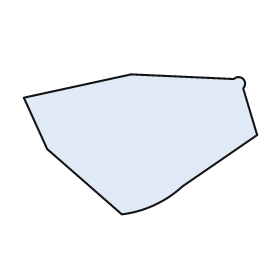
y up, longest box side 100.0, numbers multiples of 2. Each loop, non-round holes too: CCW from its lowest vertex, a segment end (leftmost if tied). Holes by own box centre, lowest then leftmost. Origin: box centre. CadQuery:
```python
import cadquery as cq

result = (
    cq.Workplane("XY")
    .moveTo(-8.0, -30.0)
    .threePointArc((6.0, -26.0), (18.0, -18.0))
    .lineTo(50.0, 4.0)
    .lineTo(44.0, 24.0)
    .threePointArc((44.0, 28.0), (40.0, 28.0))
    .lineTo(-4.0, 30.0)
    .lineTo(-50.0, 20.0)
    .lineTo(-40.0, -2.0)
    .close()
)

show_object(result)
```